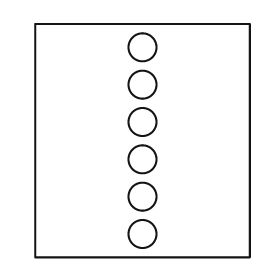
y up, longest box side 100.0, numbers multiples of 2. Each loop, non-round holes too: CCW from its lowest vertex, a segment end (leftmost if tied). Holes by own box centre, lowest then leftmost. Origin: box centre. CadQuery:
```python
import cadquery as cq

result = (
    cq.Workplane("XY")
    .moveTo(-46.0, -50.0)
    .lineTo(46.0, -50.0)
    .lineTo(46.0, 50.0)
    .lineTo(-46.0, 50.0)
    .close()
    .moveTo(0.0, -40.0)
    .circle(6.0)
    .moveTo(0.0, -24.0)
    .circle(6.0)
    .moveTo(0.0, -8.0)
    .circle(6.0)
    .moveTo(0.0, 8.0)
    .circle(6.0)
    .moveTo(0.0, 24.0)
    .circle(6.0)
    .moveTo(0.0, 40.0)
    .circle(6.0)
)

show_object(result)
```